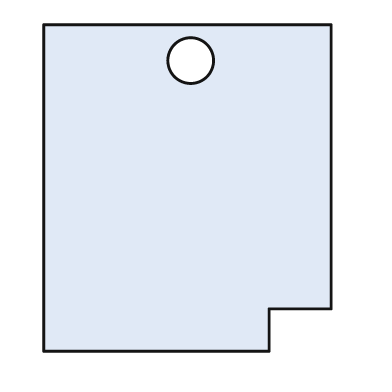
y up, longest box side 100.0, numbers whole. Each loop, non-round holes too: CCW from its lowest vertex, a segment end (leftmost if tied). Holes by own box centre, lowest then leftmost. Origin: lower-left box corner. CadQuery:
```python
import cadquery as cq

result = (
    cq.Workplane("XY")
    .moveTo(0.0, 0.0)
    .lineTo(69.0, 0.0)
    .lineTo(69.0, 13.0)
    .lineTo(88.0, 13.0)
    .lineTo(88.0, 100.0)
    .lineTo(0.0, 100.0)
    .close()
    .moveTo(45.0, 89.0)
    .circle(7.0)
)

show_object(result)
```